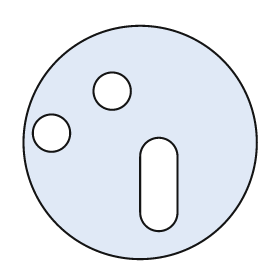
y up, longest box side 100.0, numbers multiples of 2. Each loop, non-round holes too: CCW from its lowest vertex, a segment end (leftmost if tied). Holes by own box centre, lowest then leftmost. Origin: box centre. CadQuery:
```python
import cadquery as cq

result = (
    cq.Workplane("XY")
    .moveTo(0.0, 0.0)
    .circle(50.0)
    .moveTo(0.0, -30.0)
    .threePointArc((8.0, -38.0), (16.0, -30.0))
    .lineTo(16.0, -6.0)
    .threePointArc((8.0, 2.0), (0.0, -6.0))
    .close()
    .moveTo(-38.0, 4.0)
    .circle(8.0)
    .moveTo(-12.0, 22.0)
    .circle(8.0)
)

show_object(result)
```